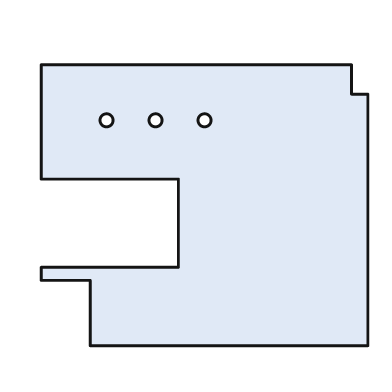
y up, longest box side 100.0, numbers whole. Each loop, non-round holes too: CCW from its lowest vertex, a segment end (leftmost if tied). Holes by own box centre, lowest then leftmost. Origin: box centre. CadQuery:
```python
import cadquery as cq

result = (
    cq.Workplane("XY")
    .moveTo(-35.0, -43.0)
    .lineTo(50.0, -43.0)
    .lineTo(50.0, 34.0)
    .lineTo(45.0, 34.0)
    .lineTo(45.0, 43.0)
    .lineTo(-50.0, 43.0)
    .lineTo(-50.0, 8.0)
    .lineTo(-8.0, 8.0)
    .lineTo(-8.0, -19.0)
    .lineTo(-50.0, -19.0)
    .lineTo(-50.0, -23.0)
    .lineTo(-35.0, -23.0)
    .close()
    .moveTo(-30.0, 26.0)
    .circle(2.0)
    .moveTo(-15.0, 26.0)
    .circle(2.0)
    .moveTo(0.0, 26.0)
    .circle(2.0)
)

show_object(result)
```